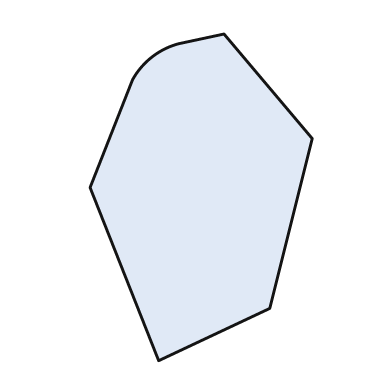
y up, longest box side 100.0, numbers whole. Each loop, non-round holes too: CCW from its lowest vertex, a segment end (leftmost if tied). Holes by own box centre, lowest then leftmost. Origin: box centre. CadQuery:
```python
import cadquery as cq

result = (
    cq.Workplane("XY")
    .moveTo(-13.0, -50.0)
    .lineTo(21.0, -34.0)
    .lineTo(34.0, 18.0)
    .lineTo(7.0, 50.0)
    .lineTo(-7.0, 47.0)
    .threePointArc((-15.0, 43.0), (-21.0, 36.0))
    .lineTo(-34.0, 3.0)
    .close()
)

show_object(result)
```